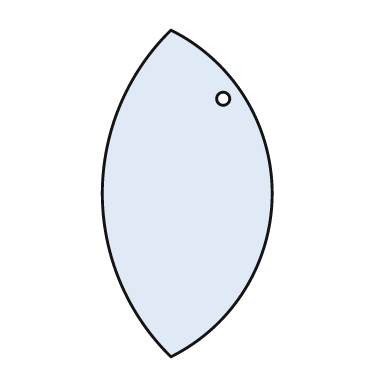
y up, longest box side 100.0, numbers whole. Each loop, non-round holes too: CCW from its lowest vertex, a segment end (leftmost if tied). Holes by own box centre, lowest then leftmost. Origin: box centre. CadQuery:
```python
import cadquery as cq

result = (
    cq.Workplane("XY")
    .moveTo(-5.0, -50.0)
    .threePointArc((26.0, 0.0), (-5.0, 50.0))
    .threePointArc((-26.0, 0.0), (-5.0, -50.0))
    .close()
    .moveTo(11.0, 29.0)
    .circle(2.0)
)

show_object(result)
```